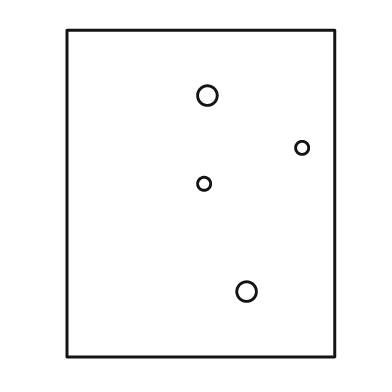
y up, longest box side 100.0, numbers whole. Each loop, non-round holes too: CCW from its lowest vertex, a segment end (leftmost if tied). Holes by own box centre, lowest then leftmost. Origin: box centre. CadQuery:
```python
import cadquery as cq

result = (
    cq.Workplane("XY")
    .moveTo(-41.0, -50.0)
    .lineTo(41.0, -50.0)
    .lineTo(41.0, 50.0)
    .lineTo(-41.0, 50.0)
    .close()
    .moveTo(14.0, -30.0)
    .circle(3.0)
    .moveTo(1.0, 3.0)
    .circle(2.0)
    .moveTo(31.0, 14.0)
    .circle(2.0)
    .moveTo(2.0, 30.0)
    .circle(3.0)
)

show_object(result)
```